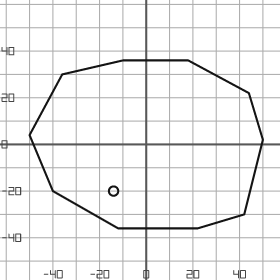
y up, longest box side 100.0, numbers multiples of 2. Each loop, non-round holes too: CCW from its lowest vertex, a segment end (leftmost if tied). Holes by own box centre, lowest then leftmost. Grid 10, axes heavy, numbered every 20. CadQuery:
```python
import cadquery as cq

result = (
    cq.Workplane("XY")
    .moveTo(-12.0, -36.0)
    .lineTo(22.0, -36.0)
    .lineTo(42.0, -30.0)
    .lineTo(50.0, 2.0)
    .lineTo(44.0, 22.0)
    .lineTo(18.0, 36.0)
    .lineTo(-10.0, 36.0)
    .lineTo(-36.0, 30.0)
    .lineTo(-50.0, 4.0)
    .lineTo(-40.0, -20.0)
    .close()
    .moveTo(-14.0, -20.0)
    .circle(2.0)
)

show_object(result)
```